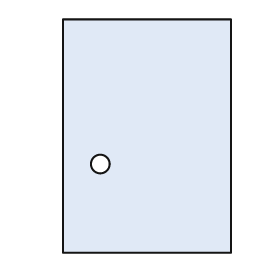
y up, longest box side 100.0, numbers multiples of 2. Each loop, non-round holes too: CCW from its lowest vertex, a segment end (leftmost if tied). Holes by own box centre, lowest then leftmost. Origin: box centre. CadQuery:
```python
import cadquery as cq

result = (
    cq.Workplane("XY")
    .moveTo(-36.0, -50.0)
    .lineTo(36.0, -50.0)
    .lineTo(36.0, 50.0)
    .lineTo(-36.0, 50.0)
    .close()
    .moveTo(-20.0, -12.0)
    .circle(4.0)
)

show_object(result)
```